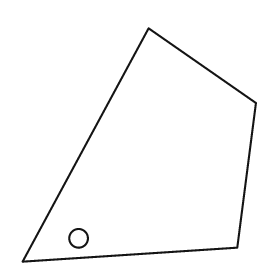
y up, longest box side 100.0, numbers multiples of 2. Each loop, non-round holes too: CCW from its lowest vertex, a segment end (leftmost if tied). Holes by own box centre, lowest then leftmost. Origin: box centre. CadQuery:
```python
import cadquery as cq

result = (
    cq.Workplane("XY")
    .moveTo(-50.0, -50.0)
    .lineTo(42.0, -44.0)
    .lineTo(50.0, 18.0)
    .lineTo(4.0, 50.0)
    .close()
    .moveTo(-26.0, -40.0)
    .circle(4.0)
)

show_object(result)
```